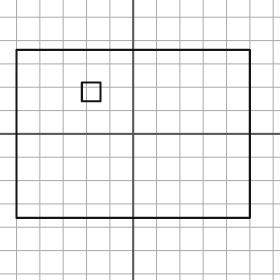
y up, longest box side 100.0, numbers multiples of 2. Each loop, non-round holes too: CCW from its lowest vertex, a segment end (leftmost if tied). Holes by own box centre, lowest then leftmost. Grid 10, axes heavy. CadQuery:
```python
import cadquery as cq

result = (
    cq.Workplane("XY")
    .moveTo(-50.0, -36.0)
    .lineTo(50.0, -36.0)
    .lineTo(50.0, 36.0)
    .lineTo(-50.0, 36.0)
    .close()
    .moveTo(-22.0, 14.0)
    .lineTo(-14.0, 14.0)
    .lineTo(-14.0, 22.0)
    .lineTo(-22.0, 22.0)
    .close()
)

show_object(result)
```